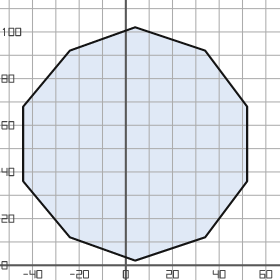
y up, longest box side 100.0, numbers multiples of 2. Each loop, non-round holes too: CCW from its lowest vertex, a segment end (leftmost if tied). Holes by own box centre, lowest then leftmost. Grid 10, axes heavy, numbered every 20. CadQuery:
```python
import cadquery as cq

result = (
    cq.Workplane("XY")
    .moveTo(4.0, 2.0)
    .lineTo(34.0, 12.0)
    .lineTo(52.0, 36.0)
    .lineTo(52.0, 68.0)
    .lineTo(34.0, 92.0)
    .lineTo(4.0, 102.0)
    .lineTo(-24.0, 92.0)
    .lineTo(-44.0, 68.0)
    .lineTo(-44.0, 36.0)
    .lineTo(-24.0, 12.0)
    .close()
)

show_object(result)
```